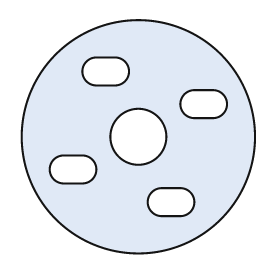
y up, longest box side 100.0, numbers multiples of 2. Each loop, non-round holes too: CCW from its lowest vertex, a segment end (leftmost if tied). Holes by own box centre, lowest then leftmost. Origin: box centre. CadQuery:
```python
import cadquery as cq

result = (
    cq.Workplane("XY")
    .moveTo(0.0, 0.0)
    .circle(50.0)
    .moveTo(10.0, -34.0)
    .lineTo(18.0, -34.0)
    .threePointArc((24.0, -28.0), (18.0, -22.0))
    .lineTo(10.0, -22.0)
    .threePointArc((4.0, -28.0), (10.0, -34.0))
    .close()
    .moveTo(-32.0, -20.0)
    .lineTo(-24.0, -20.0)
    .threePointArc((-18.0, -14.0), (-24.0, -8.0))
    .lineTo(-32.0, -8.0)
    .threePointArc((-38.0, -14.0), (-32.0, -20.0))
    .close()
    .moveTo(0.0, 0.0)
    .circle(12.0)
    .moveTo(24.0, 8.0)
    .lineTo(32.0, 8.0)
    .threePointArc((38.0, 14.0), (32.0, 20.0))
    .lineTo(24.0, 20.0)
    .threePointArc((18.0, 14.0), (24.0, 8.0))
    .close()
    .moveTo(-18.0, 22.0)
    .lineTo(-10.0, 22.0)
    .threePointArc((-4.0, 28.0), (-10.0, 34.0))
    .lineTo(-18.0, 34.0)
    .threePointArc((-24.0, 28.0), (-18.0, 22.0))
    .close()
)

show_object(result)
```